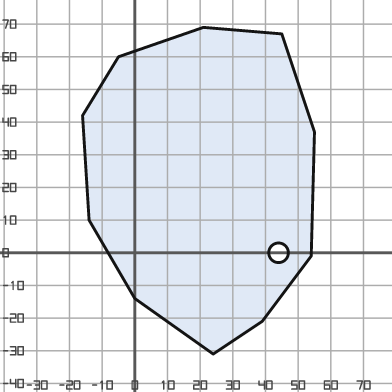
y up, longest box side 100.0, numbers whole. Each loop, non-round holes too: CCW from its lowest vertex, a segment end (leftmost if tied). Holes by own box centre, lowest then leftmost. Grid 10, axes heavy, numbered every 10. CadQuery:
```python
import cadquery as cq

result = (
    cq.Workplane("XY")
    .moveTo(24.0, -31.0)
    .lineTo(39.0, -21.0)
    .lineTo(54.0, -1.0)
    .lineTo(55.0, 37.0)
    .lineTo(45.0, 67.0)
    .lineTo(21.0, 69.0)
    .lineTo(-5.0, 60.0)
    .lineTo(-16.0, 42.0)
    .lineTo(-14.0, 10.0)
    .lineTo(0.0, -14.0)
    .close()
    .moveTo(44.0, 0.0)
    .circle(3.0)
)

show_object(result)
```